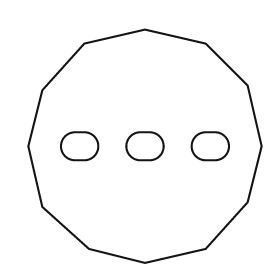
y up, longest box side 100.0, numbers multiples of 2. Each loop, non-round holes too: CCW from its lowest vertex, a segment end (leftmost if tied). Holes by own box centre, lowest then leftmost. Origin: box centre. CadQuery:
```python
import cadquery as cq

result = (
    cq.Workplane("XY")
    .moveTo(0.0, -50.0)
    .lineTo(26.0, -44.0)
    .lineTo(44.0, -24.0)
    .lineTo(50.0, 0.0)
    .lineTo(44.0, 26.0)
    .lineTo(26.0, 44.0)
    .lineTo(0.0, 50.0)
    .lineTo(-26.0, 44.0)
    .lineTo(-44.0, 24.0)
    .lineTo(-50.0, 0.0)
    .lineTo(-44.0, -26.0)
    .lineTo(-24.0, -44.0)
    .close()
    .moveTo(-30.0, -6.0)
    .lineTo(-26.0, -6.0)
    .threePointArc((-20.0, 0.0), (-26.0, 6.0))
    .lineTo(-30.0, 6.0)
    .threePointArc((-36.0, 0.0), (-30.0, -6.0))
    .close()
    .moveTo(-2.0, -6.0)
    .lineTo(2.0, -6.0)
    .threePointArc((8.0, 0.0), (2.0, 6.0))
    .lineTo(-2.0, 6.0)
    .threePointArc((-8.0, 0.0), (-2.0, -6.0))
    .close()
    .moveTo(26.0, -6.0)
    .lineTo(30.0, -6.0)
    .threePointArc((36.0, 0.0), (30.0, 6.0))
    .lineTo(26.0, 6.0)
    .threePointArc((20.0, 0.0), (26.0, -6.0))
    .close()
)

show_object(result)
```